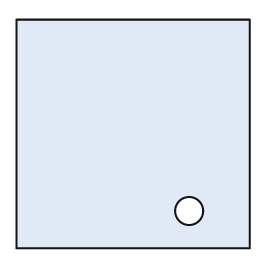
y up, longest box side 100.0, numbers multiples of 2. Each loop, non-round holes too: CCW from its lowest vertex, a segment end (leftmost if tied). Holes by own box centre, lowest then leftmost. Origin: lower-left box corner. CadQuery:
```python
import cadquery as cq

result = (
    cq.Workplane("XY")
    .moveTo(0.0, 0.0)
    .lineTo(100.0, 0.0)
    .lineTo(100.0, 98.0)
    .lineTo(0.0, 98.0)
    .close()
    .moveTo(74.0, 16.0)
    .circle(6.0)
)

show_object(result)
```